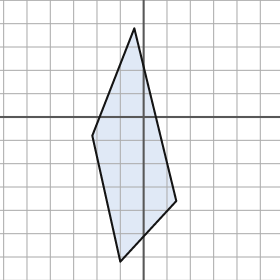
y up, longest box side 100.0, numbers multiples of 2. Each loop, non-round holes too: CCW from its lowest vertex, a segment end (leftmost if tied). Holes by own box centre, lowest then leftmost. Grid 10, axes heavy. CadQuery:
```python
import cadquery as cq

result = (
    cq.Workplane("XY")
    .moveTo(-10.0, -62.0)
    .lineTo(14.0, -36.0)
    .lineTo(-4.0, 38.0)
    .lineTo(-22.0, -8.0)
    .close()
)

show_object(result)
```